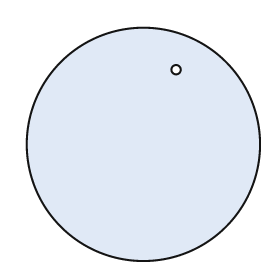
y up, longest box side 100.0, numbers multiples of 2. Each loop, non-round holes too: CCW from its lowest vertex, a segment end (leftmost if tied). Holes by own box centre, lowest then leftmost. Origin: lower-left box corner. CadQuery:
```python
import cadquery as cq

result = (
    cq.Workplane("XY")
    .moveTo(50.0, 50.0)
    .circle(50.0)
    .moveTo(64.0, 82.0)
    .circle(2.0)
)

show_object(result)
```